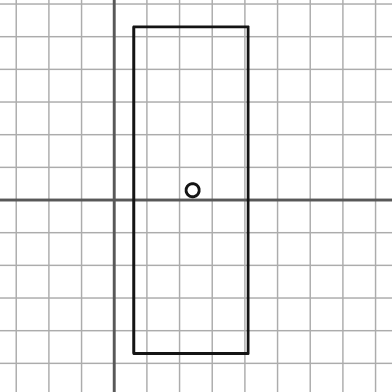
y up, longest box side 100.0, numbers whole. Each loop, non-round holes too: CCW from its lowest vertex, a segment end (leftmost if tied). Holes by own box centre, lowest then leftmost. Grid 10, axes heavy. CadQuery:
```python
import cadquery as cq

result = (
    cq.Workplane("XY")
    .moveTo(6.0, -47.0)
    .lineTo(41.0, -47.0)
    .lineTo(41.0, 53.0)
    .lineTo(6.0, 53.0)
    .close()
    .moveTo(24.0, 3.0)
    .circle(2.0)
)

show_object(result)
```